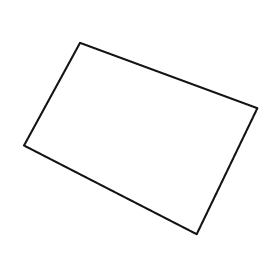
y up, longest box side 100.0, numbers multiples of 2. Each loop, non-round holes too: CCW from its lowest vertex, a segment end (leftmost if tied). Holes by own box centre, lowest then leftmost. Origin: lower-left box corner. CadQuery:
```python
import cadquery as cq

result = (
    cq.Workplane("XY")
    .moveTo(74.0, 0.0)
    .lineTo(100.0, 54.0)
    .lineTo(24.0, 82.0)
    .lineTo(0.0, 38.0)
    .close()
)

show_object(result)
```